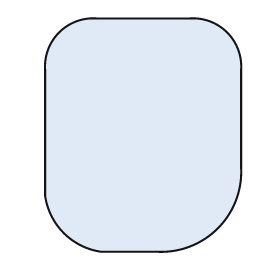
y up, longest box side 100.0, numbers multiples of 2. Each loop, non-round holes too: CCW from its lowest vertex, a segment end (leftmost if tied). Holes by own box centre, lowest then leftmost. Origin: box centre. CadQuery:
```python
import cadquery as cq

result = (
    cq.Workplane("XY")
    .moveTo(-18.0, -50.0)
    .lineTo(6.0, -50.0)
    .threePointArc((32.0, -40.0), (42.0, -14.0))
    .lineTo(42.0, 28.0)
    .threePointArc((36.0, 44.0), (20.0, 50.0))
    .lineTo(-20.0, 50.0)
    .threePointArc((-36.0, 44.0), (-42.0, 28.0))
    .lineTo(-42.0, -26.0)
    .threePointArc((-34.0, -42.0), (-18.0, -50.0))
    .close()
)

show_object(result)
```